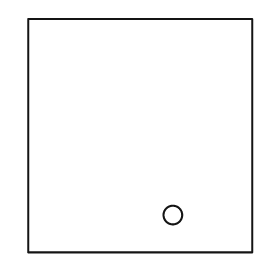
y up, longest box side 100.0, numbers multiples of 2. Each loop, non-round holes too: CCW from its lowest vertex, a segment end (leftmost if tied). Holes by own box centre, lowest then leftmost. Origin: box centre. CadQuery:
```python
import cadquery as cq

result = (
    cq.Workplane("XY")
    .moveTo(-48.0, -50.0)
    .lineTo(48.0, -50.0)
    .lineTo(48.0, 50.0)
    .lineTo(-48.0, 50.0)
    .close()
    .moveTo(14.0, -34.0)
    .circle(4.0)
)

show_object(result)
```